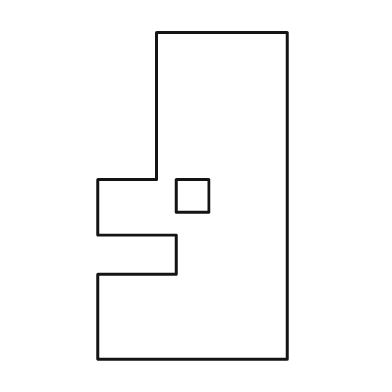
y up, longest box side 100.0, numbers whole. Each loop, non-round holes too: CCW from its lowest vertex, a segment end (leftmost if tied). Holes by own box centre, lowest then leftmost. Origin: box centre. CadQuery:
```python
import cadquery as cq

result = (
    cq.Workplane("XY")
    .moveTo(-29.0, -50.0)
    .lineTo(29.0, -50.0)
    .lineTo(29.0, 50.0)
    .lineTo(-11.0, 50.0)
    .lineTo(-11.0, 5.0)
    .lineTo(-29.0, 5.0)
    .lineTo(-29.0, -12.0)
    .lineTo(-5.0, -12.0)
    .lineTo(-5.0, -24.0)
    .lineTo(-29.0, -24.0)
    .close()
    .moveTo(-5.0, -5.0)
    .lineTo(5.0, -5.0)
    .lineTo(5.0, 5.0)
    .lineTo(-5.0, 5.0)
    .close()
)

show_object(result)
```